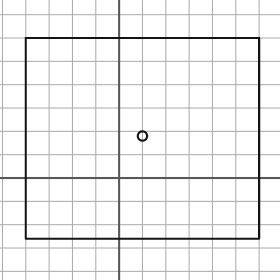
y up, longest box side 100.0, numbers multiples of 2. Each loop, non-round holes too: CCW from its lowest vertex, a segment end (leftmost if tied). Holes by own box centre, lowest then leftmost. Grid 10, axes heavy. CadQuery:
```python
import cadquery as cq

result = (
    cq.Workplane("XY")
    .moveTo(-40.0, -26.0)
    .lineTo(60.0, -26.0)
    .lineTo(60.0, 60.0)
    .lineTo(-40.0, 60.0)
    .close()
    .moveTo(10.0, 18.0)
    .circle(2.0)
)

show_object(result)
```